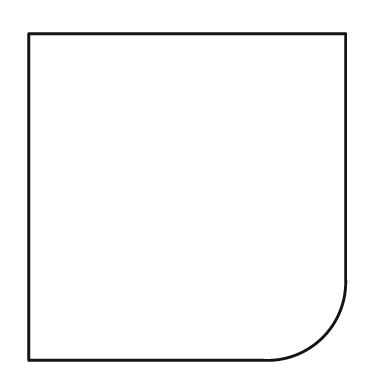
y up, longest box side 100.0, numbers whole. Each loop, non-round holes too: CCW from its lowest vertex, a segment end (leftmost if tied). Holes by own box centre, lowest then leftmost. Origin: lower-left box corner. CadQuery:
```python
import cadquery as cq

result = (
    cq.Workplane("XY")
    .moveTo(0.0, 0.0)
    .lineTo(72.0, 0.0)
    .threePointArc((90.0, 7.0), (97.0, 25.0))
    .lineTo(97.0, 100.0)
    .lineTo(0.0, 100.0)
    .close()
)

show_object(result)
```